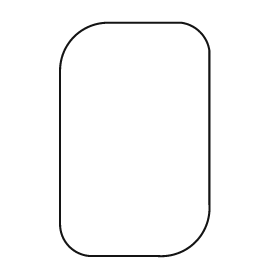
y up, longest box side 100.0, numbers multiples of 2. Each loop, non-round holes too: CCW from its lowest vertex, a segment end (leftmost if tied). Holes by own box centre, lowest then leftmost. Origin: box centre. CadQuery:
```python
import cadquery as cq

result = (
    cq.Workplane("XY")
    .moveTo(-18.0, -50.0)
    .lineTo(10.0, -50.0)
    .threePointArc((26.0, -44.0), (32.0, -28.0))
    .lineTo(32.0, 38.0)
    .threePointArc((28.0, 46.0), (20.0, 50.0))
    .lineTo(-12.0, 50.0)
    .threePointArc((-26.0, 44.0), (-32.0, 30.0))
    .lineTo(-32.0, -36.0)
    .threePointArc((-28.0, -46.0), (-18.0, -50.0))
    .close()
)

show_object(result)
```